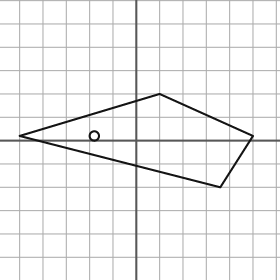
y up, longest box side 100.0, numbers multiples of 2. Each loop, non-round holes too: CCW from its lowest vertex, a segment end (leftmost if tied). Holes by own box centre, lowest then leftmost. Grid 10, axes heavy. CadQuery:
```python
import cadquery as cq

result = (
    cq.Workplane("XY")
    .moveTo(36.0, -20.0)
    .lineTo(50.0, 2.0)
    .lineTo(10.0, 20.0)
    .lineTo(-50.0, 2.0)
    .close()
    .moveTo(-18.0, 2.0)
    .circle(2.0)
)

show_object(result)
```